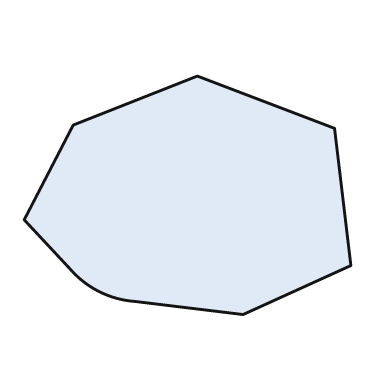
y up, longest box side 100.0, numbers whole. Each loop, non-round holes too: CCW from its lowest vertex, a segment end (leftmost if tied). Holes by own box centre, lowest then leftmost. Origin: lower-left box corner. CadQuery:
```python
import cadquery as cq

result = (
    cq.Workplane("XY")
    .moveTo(67.0, 0.0)
    .lineTo(100.0, 15.0)
    .lineTo(95.0, 57.0)
    .lineTo(53.0, 73.0)
    .lineTo(15.0, 58.0)
    .lineTo(0.0, 29.0)
    .lineTo(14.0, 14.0)
    .threePointArc((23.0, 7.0), (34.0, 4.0))
    .close()
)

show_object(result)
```